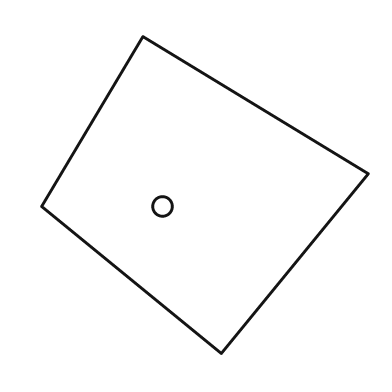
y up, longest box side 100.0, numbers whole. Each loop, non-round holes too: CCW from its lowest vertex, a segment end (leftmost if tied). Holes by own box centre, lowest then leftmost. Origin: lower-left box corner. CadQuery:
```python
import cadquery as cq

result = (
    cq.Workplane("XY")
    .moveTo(55.0, 0.0)
    .lineTo(100.0, 55.0)
    .lineTo(31.0, 97.0)
    .lineTo(0.0, 45.0)
    .close()
    .moveTo(37.0, 45.0)
    .circle(3.0)
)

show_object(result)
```